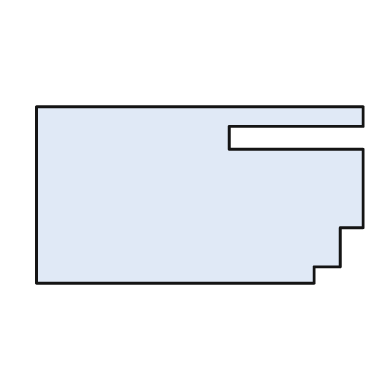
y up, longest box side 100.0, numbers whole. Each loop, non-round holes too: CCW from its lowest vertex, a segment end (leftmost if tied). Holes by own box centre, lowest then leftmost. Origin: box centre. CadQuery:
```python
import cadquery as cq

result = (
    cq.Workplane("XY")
    .moveTo(-50.0, -27.0)
    .lineTo(35.0, -27.0)
    .lineTo(35.0, -22.0)
    .lineTo(43.0, -22.0)
    .lineTo(43.0, -10.0)
    .lineTo(50.0, -10.0)
    .lineTo(50.0, 14.0)
    .lineTo(9.0, 14.0)
    .lineTo(9.0, 21.0)
    .lineTo(50.0, 21.0)
    .lineTo(50.0, 27.0)
    .lineTo(-50.0, 27.0)
    .close()
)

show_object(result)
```